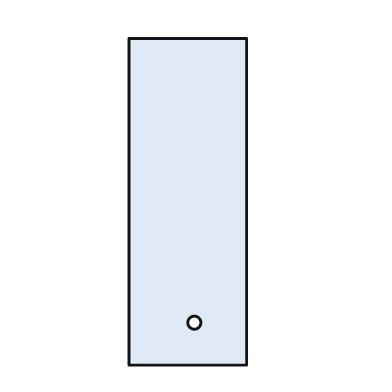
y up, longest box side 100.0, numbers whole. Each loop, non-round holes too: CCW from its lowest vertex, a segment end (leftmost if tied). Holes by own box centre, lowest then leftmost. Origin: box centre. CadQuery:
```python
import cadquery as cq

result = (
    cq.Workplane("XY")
    .moveTo(-18.0, -50.0)
    .lineTo(18.0, -50.0)
    .lineTo(18.0, 50.0)
    .lineTo(-18.0, 50.0)
    .close()
    .moveTo(2.0, -37.0)
    .circle(2.0)
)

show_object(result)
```